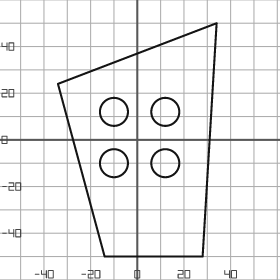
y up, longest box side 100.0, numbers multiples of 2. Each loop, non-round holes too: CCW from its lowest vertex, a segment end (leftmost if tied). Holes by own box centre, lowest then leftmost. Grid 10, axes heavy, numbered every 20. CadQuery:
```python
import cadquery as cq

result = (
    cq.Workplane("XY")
    .moveTo(-14.0, -50.0)
    .lineTo(28.0, -50.0)
    .lineTo(34.0, 50.0)
    .lineTo(-34.0, 24.0)
    .close()
    .moveTo(-10.0, -10.0)
    .circle(6.0)
    .moveTo(12.0, -10.0)
    .circle(6.0)
    .moveTo(-10.0, 12.0)
    .circle(6.0)
    .moveTo(12.0, 12.0)
    .circle(6.0)
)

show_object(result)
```